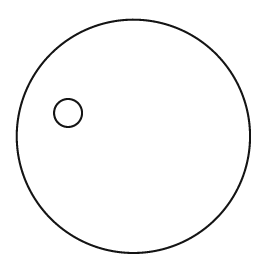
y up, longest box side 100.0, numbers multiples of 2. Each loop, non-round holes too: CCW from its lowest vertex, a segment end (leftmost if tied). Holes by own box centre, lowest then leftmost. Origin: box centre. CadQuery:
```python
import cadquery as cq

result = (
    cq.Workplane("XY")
    .moveTo(0.0, 0.0)
    .circle(50.0)
    .moveTo(-28.0, 10.0)
    .circle(6.0)
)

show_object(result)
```